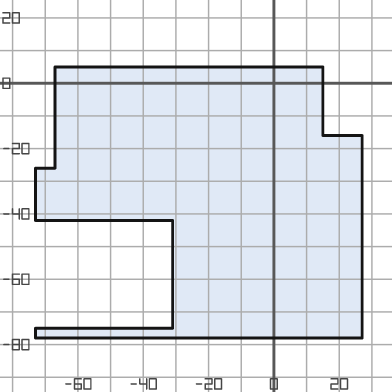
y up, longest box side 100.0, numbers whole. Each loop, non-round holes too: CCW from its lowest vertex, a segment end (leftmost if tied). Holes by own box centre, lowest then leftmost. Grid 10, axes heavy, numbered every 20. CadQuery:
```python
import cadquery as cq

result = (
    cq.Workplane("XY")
    .moveTo(-73.0, -78.0)
    .lineTo(27.0, -78.0)
    .lineTo(27.0, -16.0)
    .lineTo(15.0, -16.0)
    .lineTo(15.0, 5.0)
    .lineTo(-67.0, 5.0)
    .lineTo(-67.0, -26.0)
    .lineTo(-73.0, -26.0)
    .lineTo(-73.0, -42.0)
    .lineTo(-31.0, -42.0)
    .lineTo(-31.0, -75.0)
    .lineTo(-73.0, -75.0)
    .close()
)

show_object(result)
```